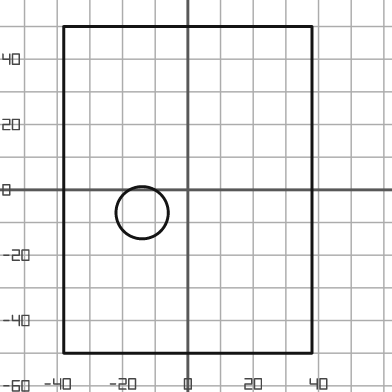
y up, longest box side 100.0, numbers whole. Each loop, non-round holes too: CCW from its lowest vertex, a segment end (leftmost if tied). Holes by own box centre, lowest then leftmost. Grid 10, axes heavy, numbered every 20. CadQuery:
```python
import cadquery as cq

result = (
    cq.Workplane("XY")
    .moveTo(-38.0, -50.0)
    .lineTo(38.0, -50.0)
    .lineTo(38.0, 50.0)
    .lineTo(-38.0, 50.0)
    .close()
    .moveTo(-14.0, -7.0)
    .circle(8.0)
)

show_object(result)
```